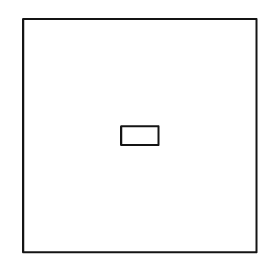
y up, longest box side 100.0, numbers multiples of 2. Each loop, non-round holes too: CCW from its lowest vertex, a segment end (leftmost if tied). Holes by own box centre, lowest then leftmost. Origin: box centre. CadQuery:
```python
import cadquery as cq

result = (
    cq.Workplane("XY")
    .moveTo(-50.0, -50.0)
    .lineTo(50.0, -50.0)
    .lineTo(50.0, 50.0)
    .lineTo(-50.0, 50.0)
    .close()
    .moveTo(-8.0, -4.0)
    .lineTo(8.0, -4.0)
    .lineTo(8.0, 4.0)
    .lineTo(-8.0, 4.0)
    .close()
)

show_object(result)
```